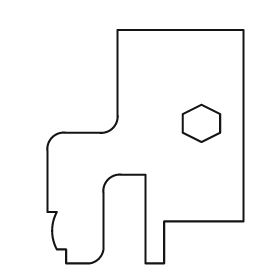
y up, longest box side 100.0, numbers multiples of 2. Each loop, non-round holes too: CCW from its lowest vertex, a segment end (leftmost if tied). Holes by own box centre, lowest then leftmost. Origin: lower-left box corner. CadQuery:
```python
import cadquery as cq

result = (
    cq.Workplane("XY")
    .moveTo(8.0, 0.0)
    .lineTo(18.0, 0.0)
    .threePointArc((22.0, 2.0), (24.0, 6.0))
    .lineTo(24.0, 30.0)
    .threePointArc((26.0, 36.0), (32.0, 38.0))
    .lineTo(42.0, 38.0)
    .lineTo(42.0, 0.0)
    .lineTo(50.0, 0.0)
    .lineTo(50.0, 18.0)
    .lineTo(84.0, 18.0)
    .lineTo(84.0, 100.0)
    .lineTo(30.0, 100.0)
    .lineTo(30.0, 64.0)
    .threePointArc((28.0, 58.0), (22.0, 56.0))
    .lineTo(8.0, 56.0)
    .threePointArc((2.0, 54.0), (0.0, 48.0))
    .lineTo(0.0, 22.0)
    .lineTo(4.0, 22.0)
    .threePointArc((2.0, 14.0), (4.0, 6.0))
    .lineTo(8.0, 6.0)
    .close()
    .moveTo(66.0, 52.0)
    .lineTo(74.0, 56.0)
    .lineTo(74.0, 64.0)
    .lineTo(66.0, 68.0)
    .lineTo(58.0, 64.0)
    .lineTo(58.0, 56.0)
    .close()
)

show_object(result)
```